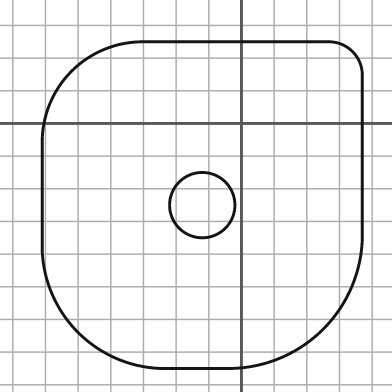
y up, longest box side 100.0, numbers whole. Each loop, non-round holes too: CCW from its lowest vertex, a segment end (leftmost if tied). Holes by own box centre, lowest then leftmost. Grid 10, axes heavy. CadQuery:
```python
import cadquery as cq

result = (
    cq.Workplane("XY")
    .moveTo(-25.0, -75.0)
    .lineTo(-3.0, -75.0)
    .threePointArc((25.0, -63.0), (37.0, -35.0))
    .lineTo(37.0, 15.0)
    .threePointArc((34.0, 22.0), (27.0, 25.0))
    .lineTo(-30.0, 25.0)
    .threePointArc((-52.0, 16.0), (-61.0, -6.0))
    .lineTo(-61.0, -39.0)
    .threePointArc((-50.0, -64.0), (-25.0, -75.0))
    .close()
    .moveTo(-12.0, -25.0)
    .circle(10.0)
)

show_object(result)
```